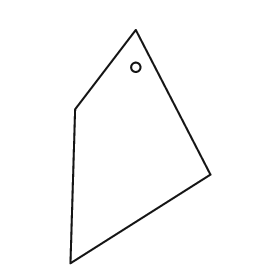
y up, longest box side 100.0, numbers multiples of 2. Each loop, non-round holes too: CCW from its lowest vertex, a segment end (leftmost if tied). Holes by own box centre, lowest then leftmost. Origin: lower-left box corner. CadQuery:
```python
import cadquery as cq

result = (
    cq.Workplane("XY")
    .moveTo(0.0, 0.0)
    .lineTo(60.0, 38.0)
    .lineTo(28.0, 100.0)
    .lineTo(2.0, 66.0)
    .close()
    .moveTo(28.0, 84.0)
    .circle(2.0)
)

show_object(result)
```